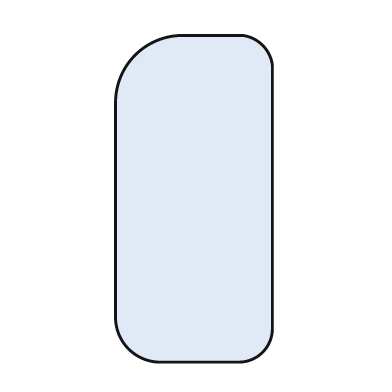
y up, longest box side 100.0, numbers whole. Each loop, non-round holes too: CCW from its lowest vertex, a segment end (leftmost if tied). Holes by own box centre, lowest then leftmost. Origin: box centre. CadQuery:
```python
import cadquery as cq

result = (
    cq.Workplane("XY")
    .moveTo(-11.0, -50.0)
    .lineTo(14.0, -50.0)
    .threePointArc((21.0, -47.0), (24.0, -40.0))
    .lineTo(24.0, 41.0)
    .threePointArc((21.0, 47.0), (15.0, 50.0))
    .lineTo(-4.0, 50.0)
    .threePointArc((-18.0, 44.0), (-24.0, 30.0))
    .lineTo(-24.0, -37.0)
    .threePointArc((-20.0, -46.0), (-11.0, -50.0))
    .close()
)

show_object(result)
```